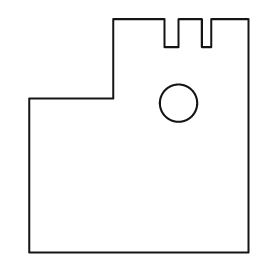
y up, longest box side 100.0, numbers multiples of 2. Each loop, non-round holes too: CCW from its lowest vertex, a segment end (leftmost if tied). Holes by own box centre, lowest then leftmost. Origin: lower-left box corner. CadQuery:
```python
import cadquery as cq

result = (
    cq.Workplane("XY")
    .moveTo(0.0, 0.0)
    .lineTo(94.0, 0.0)
    .lineTo(94.0, 100.0)
    .lineTo(78.0, 100.0)
    .lineTo(78.0, 88.0)
    .lineTo(74.0, 88.0)
    .lineTo(74.0, 100.0)
    .lineTo(64.0, 100.0)
    .lineTo(64.0, 88.0)
    .lineTo(58.0, 88.0)
    .lineTo(58.0, 100.0)
    .lineTo(36.0, 100.0)
    .lineTo(36.0, 66.0)
    .lineTo(0.0, 66.0)
    .close()
    .moveTo(64.0, 64.0)
    .circle(8.0)
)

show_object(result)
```